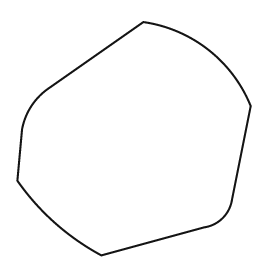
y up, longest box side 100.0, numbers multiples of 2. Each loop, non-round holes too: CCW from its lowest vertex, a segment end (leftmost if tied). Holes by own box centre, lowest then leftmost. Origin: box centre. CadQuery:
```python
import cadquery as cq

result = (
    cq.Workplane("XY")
    .moveTo(-14.0, -50.0)
    .lineTo(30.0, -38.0)
    .threePointArc((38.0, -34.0), (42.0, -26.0))
    .lineTo(50.0, 14.0)
    .threePointArc((32.0, 38.0), (4.0, 50.0))
    .lineTo(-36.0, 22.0)
    .threePointArc((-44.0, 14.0), (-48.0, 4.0))
    .lineTo(-50.0, -18.0)
    .threePointArc((-34.0, -36.0), (-14.0, -50.0))
    .close()
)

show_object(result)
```